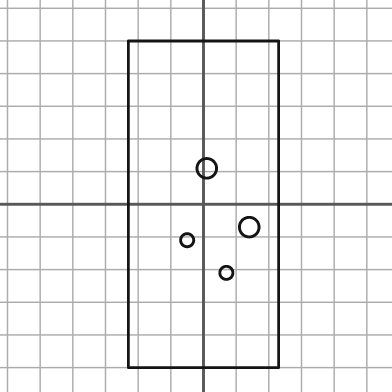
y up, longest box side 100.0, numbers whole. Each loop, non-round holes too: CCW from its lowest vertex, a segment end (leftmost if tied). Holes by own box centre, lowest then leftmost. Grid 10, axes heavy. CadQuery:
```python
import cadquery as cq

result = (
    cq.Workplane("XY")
    .moveTo(-23.0, -50.0)
    .lineTo(23.0, -50.0)
    .lineTo(23.0, 50.0)
    .lineTo(-23.0, 50.0)
    .close()
    .moveTo(7.0, -21.0)
    .circle(2.0)
    .moveTo(-5.0, -11.0)
    .circle(2.0)
    .moveTo(14.0, -7.0)
    .circle(3.0)
    .moveTo(1.0, 11.0)
    .circle(3.0)
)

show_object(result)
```